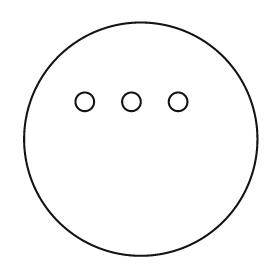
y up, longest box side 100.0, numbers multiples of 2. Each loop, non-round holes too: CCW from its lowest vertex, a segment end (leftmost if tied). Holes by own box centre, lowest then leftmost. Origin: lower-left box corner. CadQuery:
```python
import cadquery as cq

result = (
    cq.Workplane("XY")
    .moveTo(50.0, 50.0)
    .circle(50.0)
    .moveTo(26.0, 66.0)
    .circle(4.0)
    .moveTo(46.0, 66.0)
    .circle(4.0)
    .moveTo(66.0, 66.0)
    .circle(4.0)
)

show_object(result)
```